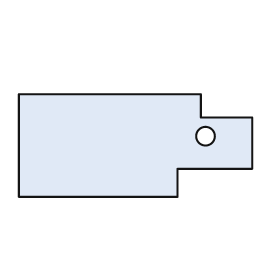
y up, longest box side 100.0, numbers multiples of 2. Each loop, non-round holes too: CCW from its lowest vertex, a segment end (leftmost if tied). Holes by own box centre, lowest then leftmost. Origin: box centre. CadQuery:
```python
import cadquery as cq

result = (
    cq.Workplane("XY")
    .moveTo(-50.0, -22.0)
    .lineTo(18.0, -22.0)
    .lineTo(18.0, -10.0)
    .lineTo(50.0, -10.0)
    .lineTo(50.0, 12.0)
    .lineTo(28.0, 12.0)
    .lineTo(28.0, 22.0)
    .lineTo(-50.0, 22.0)
    .close()
    .moveTo(30.0, 4.0)
    .circle(4.0)
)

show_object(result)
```